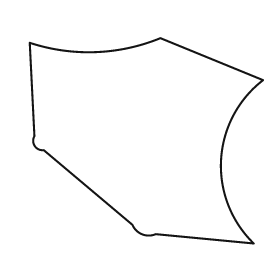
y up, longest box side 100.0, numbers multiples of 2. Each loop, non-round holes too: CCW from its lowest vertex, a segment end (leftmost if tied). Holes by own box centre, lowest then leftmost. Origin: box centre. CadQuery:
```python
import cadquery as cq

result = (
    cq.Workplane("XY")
    .moveTo(46.0, -44.0)
    .threePointArc((32.0, -8.0), (50.0, 26.0))
    .lineTo(6.0, 44.0)
    .threePointArc((-22.0, 38.0), (-50.0, 42.0))
    .lineTo(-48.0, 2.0)
    .threePointArc((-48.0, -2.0), (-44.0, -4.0))
    .lineTo(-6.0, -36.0)
    .threePointArc((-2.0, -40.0), (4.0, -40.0))
    .close()
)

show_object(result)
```